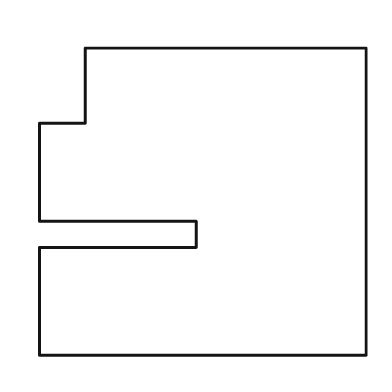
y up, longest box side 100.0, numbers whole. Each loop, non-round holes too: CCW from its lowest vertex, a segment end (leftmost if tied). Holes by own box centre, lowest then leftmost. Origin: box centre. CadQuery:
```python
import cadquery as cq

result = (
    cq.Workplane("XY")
    .moveTo(-50.0, -47.0)
    .lineTo(50.0, -47.0)
    .lineTo(50.0, 47.0)
    .lineTo(-36.0, 47.0)
    .lineTo(-36.0, 24.0)
    .lineTo(-50.0, 24.0)
    .lineTo(-50.0, -6.0)
    .lineTo(-2.0, -6.0)
    .lineTo(-2.0, -14.0)
    .lineTo(-50.0, -14.0)
    .close()
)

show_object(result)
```